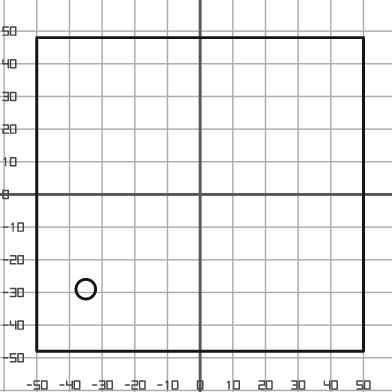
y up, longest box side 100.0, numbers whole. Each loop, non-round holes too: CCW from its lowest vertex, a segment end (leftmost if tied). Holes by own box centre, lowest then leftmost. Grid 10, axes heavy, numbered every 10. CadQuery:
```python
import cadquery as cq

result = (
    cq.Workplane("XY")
    .moveTo(-50.0, -48.0)
    .lineTo(50.0, -48.0)
    .lineTo(50.0, 48.0)
    .lineTo(-50.0, 48.0)
    .close()
    .moveTo(-35.0, -29.0)
    .circle(3.0)
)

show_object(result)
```